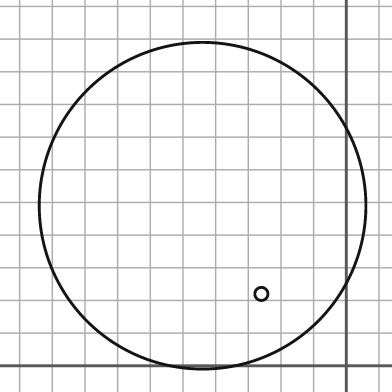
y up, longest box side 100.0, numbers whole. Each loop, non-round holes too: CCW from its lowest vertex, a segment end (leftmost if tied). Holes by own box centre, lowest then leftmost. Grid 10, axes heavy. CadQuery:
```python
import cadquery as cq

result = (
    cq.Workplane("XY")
    .moveTo(-44.0, 49.0)
    .circle(50.0)
    .moveTo(-26.0, 22.0)
    .circle(2.0)
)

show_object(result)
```